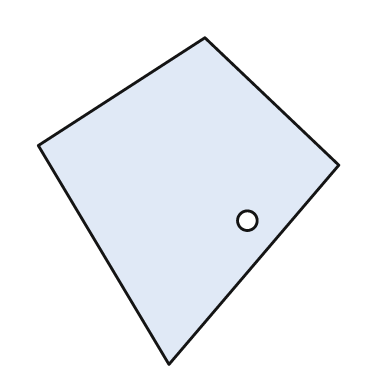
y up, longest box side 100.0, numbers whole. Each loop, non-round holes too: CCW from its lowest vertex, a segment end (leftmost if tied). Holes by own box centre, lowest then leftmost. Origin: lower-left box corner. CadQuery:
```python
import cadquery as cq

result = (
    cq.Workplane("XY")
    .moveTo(40.0, 0.0)
    .lineTo(92.0, 61.0)
    .lineTo(51.0, 100.0)
    .lineTo(0.0, 67.0)
    .close()
    .moveTo(64.0, 44.0)
    .circle(3.0)
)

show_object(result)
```